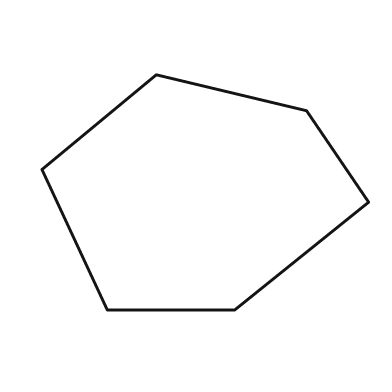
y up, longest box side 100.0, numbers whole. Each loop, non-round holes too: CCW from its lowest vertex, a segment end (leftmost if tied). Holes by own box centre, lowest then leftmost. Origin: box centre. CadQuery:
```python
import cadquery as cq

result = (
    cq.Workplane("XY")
    .moveTo(-30.0, -36.0)
    .lineTo(9.0, -36.0)
    .lineTo(50.0, -3.0)
    .lineTo(31.0, 25.0)
    .lineTo(-15.0, 36.0)
    .lineTo(-50.0, 7.0)
    .close()
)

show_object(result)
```